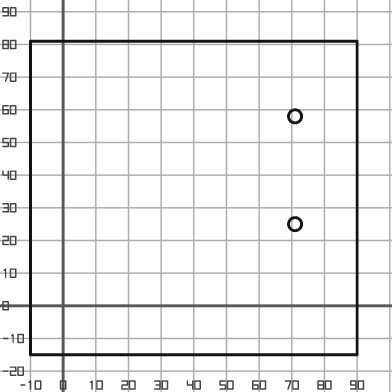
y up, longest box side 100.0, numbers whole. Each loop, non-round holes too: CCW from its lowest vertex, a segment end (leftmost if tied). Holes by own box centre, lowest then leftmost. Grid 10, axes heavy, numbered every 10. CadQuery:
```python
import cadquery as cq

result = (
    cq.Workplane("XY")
    .moveTo(-10.0, -15.0)
    .lineTo(90.0, -15.0)
    .lineTo(90.0, 81.0)
    .lineTo(-10.0, 81.0)
    .close()
    .moveTo(71.0, 25.0)
    .circle(2.0)
    .moveTo(71.0, 58.0)
    .circle(2.0)
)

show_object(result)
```